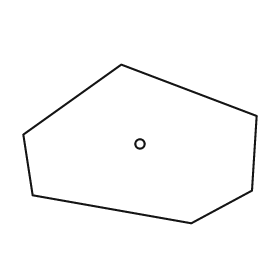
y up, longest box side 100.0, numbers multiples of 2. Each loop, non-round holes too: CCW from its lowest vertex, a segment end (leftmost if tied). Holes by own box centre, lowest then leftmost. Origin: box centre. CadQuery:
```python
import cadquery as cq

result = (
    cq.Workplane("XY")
    .moveTo(22.0, -34.0)
    .lineTo(48.0, -20.0)
    .lineTo(50.0, 12.0)
    .lineTo(-8.0, 34.0)
    .lineTo(-50.0, 4.0)
    .lineTo(-46.0, -22.0)
    .close()
    .moveTo(0.0, 0.0)
    .circle(2.0)
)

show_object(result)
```